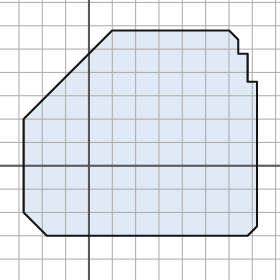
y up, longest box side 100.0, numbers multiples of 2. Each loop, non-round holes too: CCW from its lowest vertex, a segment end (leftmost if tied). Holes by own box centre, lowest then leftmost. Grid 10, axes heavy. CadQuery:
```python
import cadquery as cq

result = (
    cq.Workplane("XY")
    .moveTo(-18.0, -30.0)
    .lineTo(68.0, -30.0)
    .lineTo(72.0, -26.0)
    .lineTo(72.0, 36.0)
    .lineTo(68.0, 36.0)
    .lineTo(68.0, 48.0)
    .lineTo(64.0, 48.0)
    .lineTo(64.0, 54.0)
    .lineTo(60.0, 58.0)
    .lineTo(10.0, 58.0)
    .lineTo(-28.0, 20.0)
    .lineTo(-28.0, -20.0)
    .close()
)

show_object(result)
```